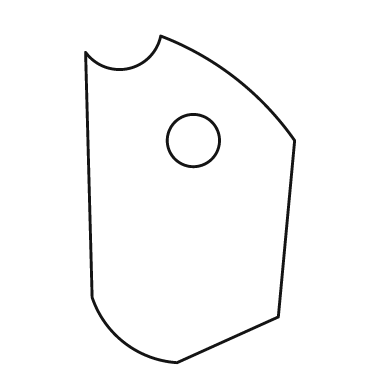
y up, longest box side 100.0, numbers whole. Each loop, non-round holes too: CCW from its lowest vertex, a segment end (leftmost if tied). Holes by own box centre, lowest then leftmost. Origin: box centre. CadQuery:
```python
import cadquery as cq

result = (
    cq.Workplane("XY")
    .moveTo(-4.0, -50.0)
    .lineTo(27.0, -36.0)
    .lineTo(32.0, 18.0)
    .threePointArc((14.0, 37.0), (-9.0, 50.0))
    .threePointArc((-19.0, 40.0), (-32.0, 45.0))
    .lineTo(-30.0, -30.0)
    .threePointArc((-20.0, -44.0), (-4.0, -50.0))
    .close()
    .moveTo(1.0, 18.0)
    .circle(8.0)
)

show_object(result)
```